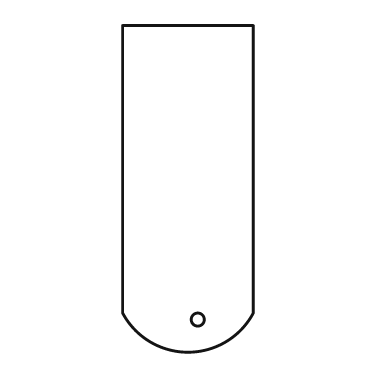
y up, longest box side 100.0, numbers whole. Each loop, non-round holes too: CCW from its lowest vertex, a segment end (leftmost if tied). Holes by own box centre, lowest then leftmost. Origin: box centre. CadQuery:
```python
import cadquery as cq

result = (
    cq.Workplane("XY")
    .moveTo(-20.0, -38.0)
    .threePointArc((0.0, -50.0), (20.0, -38.0))
    .lineTo(20.0, 50.0)
    .lineTo(-20.0, 50.0)
    .close()
    .moveTo(3.0, -40.0)
    .circle(2.0)
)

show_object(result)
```